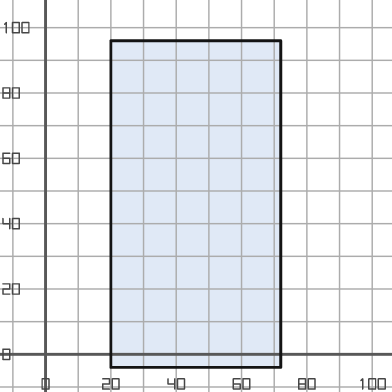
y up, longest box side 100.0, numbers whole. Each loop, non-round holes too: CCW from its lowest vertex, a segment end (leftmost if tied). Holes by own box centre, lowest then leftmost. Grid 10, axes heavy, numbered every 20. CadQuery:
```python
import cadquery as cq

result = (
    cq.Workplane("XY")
    .moveTo(20.0, -4.0)
    .lineTo(72.0, -4.0)
    .lineTo(72.0, 96.0)
    .lineTo(20.0, 96.0)
    .close()
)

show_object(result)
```